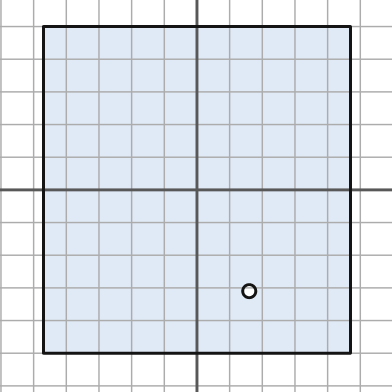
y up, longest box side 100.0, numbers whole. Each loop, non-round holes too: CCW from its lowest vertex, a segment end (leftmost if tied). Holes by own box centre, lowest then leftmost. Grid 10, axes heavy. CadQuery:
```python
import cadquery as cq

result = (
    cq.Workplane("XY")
    .moveTo(-47.0, -50.0)
    .lineTo(47.0, -50.0)
    .lineTo(47.0, 50.0)
    .lineTo(-47.0, 50.0)
    .close()
    .moveTo(16.0, -31.0)
    .circle(2.0)
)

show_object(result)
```